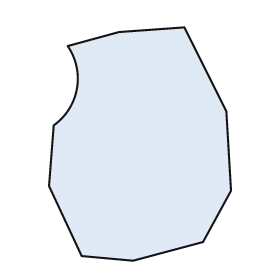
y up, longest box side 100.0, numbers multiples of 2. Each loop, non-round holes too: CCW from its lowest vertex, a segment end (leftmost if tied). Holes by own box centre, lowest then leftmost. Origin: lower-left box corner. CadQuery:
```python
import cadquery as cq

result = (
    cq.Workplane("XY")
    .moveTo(36.0, 0.0)
    .lineTo(66.0, 8.0)
    .lineTo(78.0, 30.0)
    .lineTo(76.0, 64.0)
    .lineTo(58.0, 100.0)
    .lineTo(30.0, 98.0)
    .lineTo(8.0, 92.0)
    .threePointArc((12.0, 74.0), (2.0, 58.0))
    .lineTo(0.0, 32.0)
    .lineTo(14.0, 2.0)
    .close()
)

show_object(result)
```